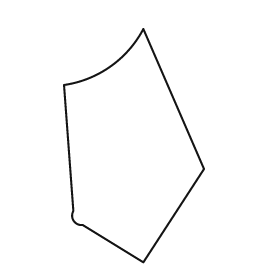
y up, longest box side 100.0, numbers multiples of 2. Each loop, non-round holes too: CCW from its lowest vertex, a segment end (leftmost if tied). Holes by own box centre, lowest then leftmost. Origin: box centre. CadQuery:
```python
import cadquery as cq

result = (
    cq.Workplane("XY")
    .moveTo(4.0, -50.0)
    .lineTo(30.0, -10.0)
    .lineTo(4.0, 50.0)
    .threePointArc((-10.0, 34.0), (-30.0, 26.0))
    .lineTo(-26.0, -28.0)
    .threePointArc((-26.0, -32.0), (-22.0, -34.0))
    .close()
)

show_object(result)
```